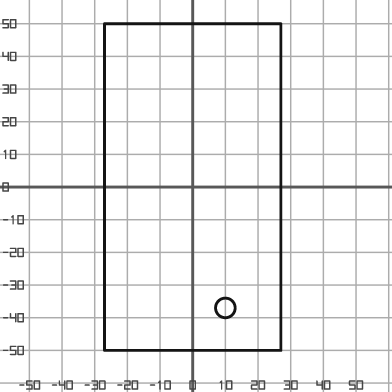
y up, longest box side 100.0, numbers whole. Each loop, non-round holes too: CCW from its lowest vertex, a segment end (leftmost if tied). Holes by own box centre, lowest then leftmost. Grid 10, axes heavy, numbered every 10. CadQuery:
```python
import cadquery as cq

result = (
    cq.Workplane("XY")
    .moveTo(-27.0, -50.0)
    .lineTo(27.0, -50.0)
    .lineTo(27.0, 50.0)
    .lineTo(-27.0, 50.0)
    .close()
    .moveTo(10.0, -37.0)
    .circle(3.0)
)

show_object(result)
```